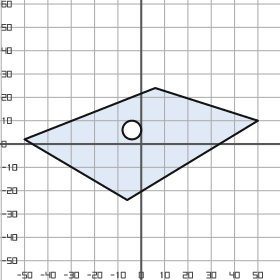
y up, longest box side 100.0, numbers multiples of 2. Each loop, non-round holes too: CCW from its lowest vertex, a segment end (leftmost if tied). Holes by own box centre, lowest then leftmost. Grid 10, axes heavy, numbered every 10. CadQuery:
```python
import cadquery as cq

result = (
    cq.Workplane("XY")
    .moveTo(-6.0, -24.0)
    .lineTo(50.0, 10.0)
    .lineTo(6.0, 24.0)
    .lineTo(-50.0, 2.0)
    .close()
    .moveTo(-4.0, 6.0)
    .circle(4.0)
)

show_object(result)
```